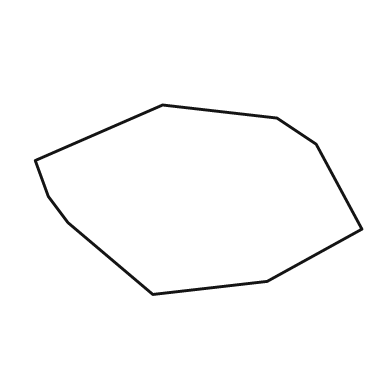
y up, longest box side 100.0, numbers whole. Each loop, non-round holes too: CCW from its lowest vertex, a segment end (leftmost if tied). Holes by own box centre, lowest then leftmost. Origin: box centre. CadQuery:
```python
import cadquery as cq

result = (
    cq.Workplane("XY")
    .moveTo(-14.0, -29.0)
    .lineTo(21.0, -25.0)
    .lineTo(50.0, -9.0)
    .lineTo(36.0, 17.0)
    .lineTo(24.0, 25.0)
    .lineTo(-11.0, 29.0)
    .lineTo(-50.0, 12.0)
    .lineTo(-46.0, 1.0)
    .lineTo(-40.0, -7.0)
    .close()
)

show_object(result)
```